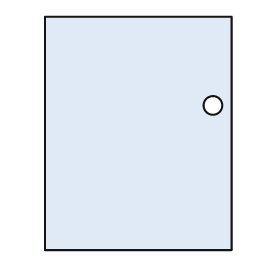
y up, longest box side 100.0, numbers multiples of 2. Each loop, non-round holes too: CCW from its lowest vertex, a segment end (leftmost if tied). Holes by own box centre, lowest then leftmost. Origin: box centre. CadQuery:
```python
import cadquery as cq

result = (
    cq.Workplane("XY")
    .moveTo(-40.0, -50.0)
    .lineTo(40.0, -50.0)
    .lineTo(40.0, 50.0)
    .lineTo(-40.0, 50.0)
    .close()
    .moveTo(32.0, 12.0)
    .circle(4.0)
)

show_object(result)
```